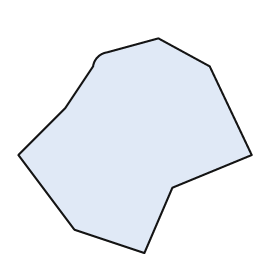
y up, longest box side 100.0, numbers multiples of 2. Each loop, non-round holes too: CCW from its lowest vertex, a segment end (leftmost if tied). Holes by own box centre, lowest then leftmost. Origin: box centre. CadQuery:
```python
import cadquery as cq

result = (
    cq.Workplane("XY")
    .moveTo(4.0, -46.0)
    .lineTo(16.0, -18.0)
    .lineTo(50.0, -4.0)
    .lineTo(32.0, 34.0)
    .lineTo(10.0, 46.0)
    .lineTo(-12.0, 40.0)
    .threePointArc((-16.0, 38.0), (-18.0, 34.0))
    .lineTo(-30.0, 16.0)
    .lineTo(-50.0, -4.0)
    .lineTo(-26.0, -36.0)
    .close()
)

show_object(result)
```